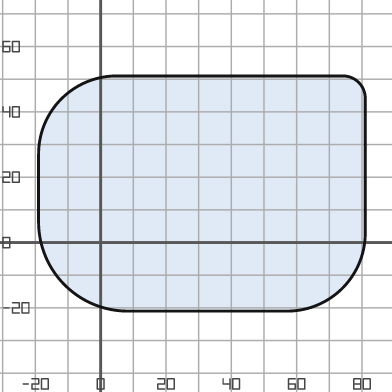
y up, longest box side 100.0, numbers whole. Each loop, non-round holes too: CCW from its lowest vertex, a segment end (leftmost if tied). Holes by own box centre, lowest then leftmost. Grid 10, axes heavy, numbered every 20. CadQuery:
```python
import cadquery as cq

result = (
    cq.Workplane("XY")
    .moveTo(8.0, -21.0)
    .lineTo(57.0, -21.0)
    .threePointArc((74.0, -14.0), (81.0, 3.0))
    .lineTo(81.0, 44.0)
    .threePointArc((79.0, 49.0), (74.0, 51.0))
    .lineTo(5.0, 51.0)
    .threePointArc((-12.0, 44.0), (-19.0, 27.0))
    .lineTo(-19.0, 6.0)
    .threePointArc((-11.0, -13.0), (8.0, -21.0))
    .close()
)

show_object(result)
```